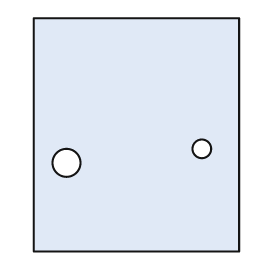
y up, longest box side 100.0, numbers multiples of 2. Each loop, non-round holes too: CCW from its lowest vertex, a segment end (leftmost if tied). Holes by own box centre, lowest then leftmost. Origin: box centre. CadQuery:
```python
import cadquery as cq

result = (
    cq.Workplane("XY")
    .moveTo(-44.0, -50.0)
    .lineTo(44.0, -50.0)
    .lineTo(44.0, 50.0)
    .lineTo(-44.0, 50.0)
    .close()
    .moveTo(-30.0, -12.0)
    .circle(6.0)
    .moveTo(28.0, -6.0)
    .circle(4.0)
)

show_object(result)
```